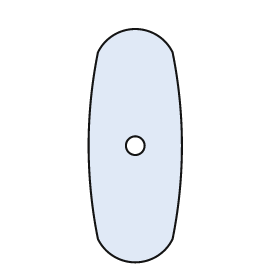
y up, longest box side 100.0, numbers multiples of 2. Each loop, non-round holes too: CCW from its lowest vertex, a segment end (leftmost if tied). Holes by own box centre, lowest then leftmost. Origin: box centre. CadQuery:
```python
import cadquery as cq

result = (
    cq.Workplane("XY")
    .moveTo(-16.0, -40.0)
    .threePointArc((0.0, -50.0), (16.0, -40.0))
    .threePointArc((20.0, 0.0), (16.0, 40.0))
    .threePointArc((0.0, 50.0), (-16.0, 40.0))
    .threePointArc((-20.0, 0.0), (-16.0, -40.0))
    .close()
    .moveTo(0.0, 0.0)
    .circle(4.0)
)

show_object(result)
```